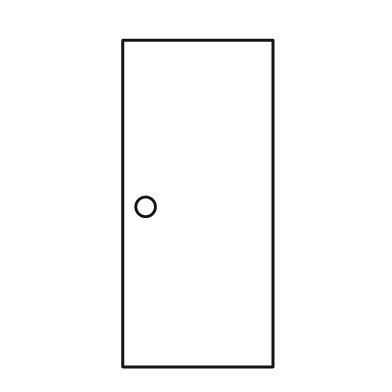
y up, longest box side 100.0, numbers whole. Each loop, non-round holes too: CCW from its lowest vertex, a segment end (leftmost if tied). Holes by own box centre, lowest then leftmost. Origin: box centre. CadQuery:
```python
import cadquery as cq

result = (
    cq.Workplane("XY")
    .moveTo(-23.0, -50.0)
    .lineTo(23.0, -50.0)
    .lineTo(23.0, 50.0)
    .lineTo(-23.0, 50.0)
    .close()
    .moveTo(-16.0, -1.0)
    .circle(3.0)
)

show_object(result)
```